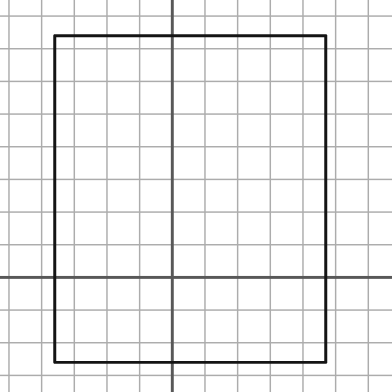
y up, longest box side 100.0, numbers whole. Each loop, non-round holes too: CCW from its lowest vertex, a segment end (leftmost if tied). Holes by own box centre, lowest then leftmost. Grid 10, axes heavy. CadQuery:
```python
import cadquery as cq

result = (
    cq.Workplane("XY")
    .moveTo(-36.0, -26.0)
    .lineTo(47.0, -26.0)
    .lineTo(47.0, 74.0)
    .lineTo(-36.0, 74.0)
    .close()
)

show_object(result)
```